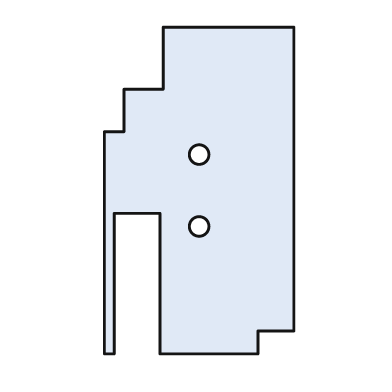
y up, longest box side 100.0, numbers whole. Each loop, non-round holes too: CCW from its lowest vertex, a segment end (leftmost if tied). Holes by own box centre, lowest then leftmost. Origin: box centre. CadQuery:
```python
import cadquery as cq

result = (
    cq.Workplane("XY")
    .moveTo(-29.0, -50.0)
    .lineTo(-26.0, -50.0)
    .lineTo(-26.0, -7.0)
    .lineTo(-12.0, -7.0)
    .lineTo(-12.0, -50.0)
    .lineTo(18.0, -50.0)
    .lineTo(18.0, -43.0)
    .lineTo(29.0, -43.0)
    .lineTo(29.0, 50.0)
    .lineTo(-11.0, 50.0)
    .lineTo(-11.0, 31.0)
    .lineTo(-23.0, 31.0)
    .lineTo(-23.0, 18.0)
    .lineTo(-29.0, 18.0)
    .close()
    .moveTo(0.0, -11.0)
    .circle(3.0)
    .moveTo(0.0, 11.0)
    .circle(3.0)
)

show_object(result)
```